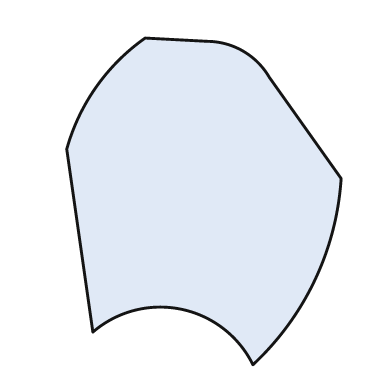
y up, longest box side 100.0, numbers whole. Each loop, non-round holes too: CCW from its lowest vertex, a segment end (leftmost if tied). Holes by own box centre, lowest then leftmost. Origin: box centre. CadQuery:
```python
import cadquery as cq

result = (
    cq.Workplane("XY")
    .moveTo(15.0, -50.0)
    .threePointArc((34.0, -24.0), (42.0, 7.0))
    .lineTo(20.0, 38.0)
    .threePointArc((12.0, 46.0), (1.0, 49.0))
    .lineTo(-18.0, 50.0)
    .threePointArc((-33.0, 35.0), (-42.0, 16.0))
    .lineTo(-34.0, -40.0)
    .threePointArc((-7.0, -33.0), (15.0, -50.0))
    .close()
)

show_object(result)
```